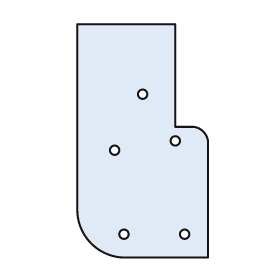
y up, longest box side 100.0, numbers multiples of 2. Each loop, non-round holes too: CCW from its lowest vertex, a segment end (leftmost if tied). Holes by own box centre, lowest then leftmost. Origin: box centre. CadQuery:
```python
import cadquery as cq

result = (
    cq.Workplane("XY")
    .moveTo(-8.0, -50.0)
    .lineTo(28.0, -50.0)
    .lineTo(28.0, 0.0)
    .threePointArc((26.0, 4.0), (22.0, 6.0))
    .lineTo(14.0, 6.0)
    .lineTo(14.0, 50.0)
    .lineTo(-28.0, 50.0)
    .lineTo(-28.0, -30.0)
    .threePointArc((-22.0, -44.0), (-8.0, -50.0))
    .close()
    .moveTo(-8.0, -40.0)
    .circle(2.0)
    .moveTo(18.0, -40.0)
    .circle(2.0)
    .moveTo(-12.0, -4.0)
    .circle(2.0)
    .moveTo(14.0, 0.0)
    .circle(2.0)
    .moveTo(0.0, 20.0)
    .circle(2.0)
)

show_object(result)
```